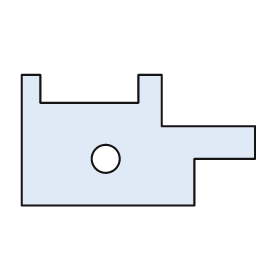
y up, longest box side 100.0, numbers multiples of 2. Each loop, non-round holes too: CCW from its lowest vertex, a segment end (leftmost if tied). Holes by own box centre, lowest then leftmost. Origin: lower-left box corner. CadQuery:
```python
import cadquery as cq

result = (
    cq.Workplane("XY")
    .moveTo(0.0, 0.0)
    .lineTo(74.0, 0.0)
    .lineTo(74.0, 20.0)
    .lineTo(100.0, 20.0)
    .lineTo(100.0, 34.0)
    .lineTo(60.0, 34.0)
    .lineTo(60.0, 56.0)
    .lineTo(50.0, 56.0)
    .lineTo(50.0, 44.0)
    .lineTo(8.0, 44.0)
    .lineTo(8.0, 56.0)
    .lineTo(0.0, 56.0)
    .close()
    .moveTo(36.0, 20.0)
    .circle(6.0)
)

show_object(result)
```